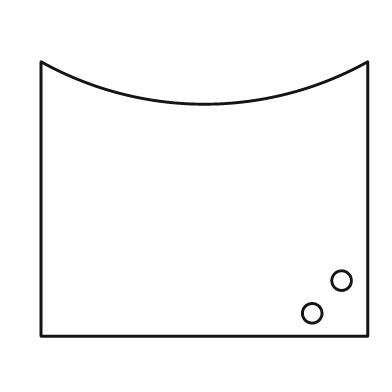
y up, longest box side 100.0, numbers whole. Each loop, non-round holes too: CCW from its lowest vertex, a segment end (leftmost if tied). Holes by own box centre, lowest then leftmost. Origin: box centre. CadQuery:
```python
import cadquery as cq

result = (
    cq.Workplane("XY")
    .moveTo(-50.0, -42.0)
    .lineTo(50.0, -42.0)
    .lineTo(50.0, 42.0)
    .threePointArc((0.0, 29.0), (-50.0, 42.0))
    .close()
    .moveTo(33.0, -35.0)
    .circle(3.0)
    .moveTo(42.0, -25.0)
    .circle(3.0)
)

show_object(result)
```